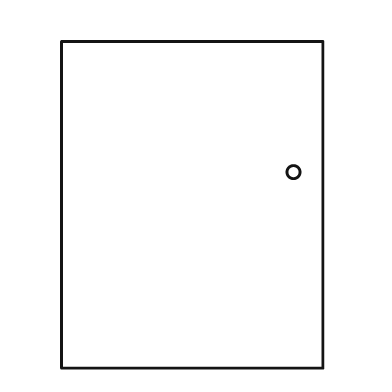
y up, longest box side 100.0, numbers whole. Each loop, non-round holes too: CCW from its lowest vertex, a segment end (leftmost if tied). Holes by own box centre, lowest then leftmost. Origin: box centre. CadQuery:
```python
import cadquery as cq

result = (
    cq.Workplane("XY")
    .moveTo(-40.0, -50.0)
    .lineTo(40.0, -50.0)
    .lineTo(40.0, 50.0)
    .lineTo(-40.0, 50.0)
    .close()
    .moveTo(31.0, 10.0)
    .circle(2.0)
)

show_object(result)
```